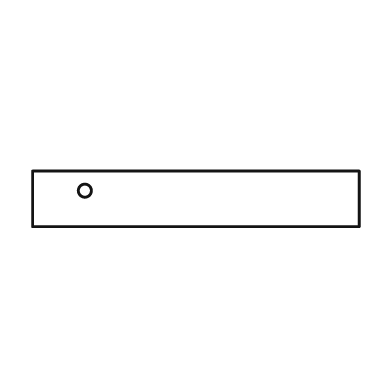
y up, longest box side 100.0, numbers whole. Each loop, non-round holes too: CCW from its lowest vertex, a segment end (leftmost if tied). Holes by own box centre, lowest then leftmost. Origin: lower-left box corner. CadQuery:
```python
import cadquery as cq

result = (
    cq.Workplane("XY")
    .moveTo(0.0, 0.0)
    .lineTo(100.0, 0.0)
    .lineTo(100.0, 17.0)
    .lineTo(0.0, 17.0)
    .close()
    .moveTo(16.0, 11.0)
    .circle(2.0)
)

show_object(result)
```